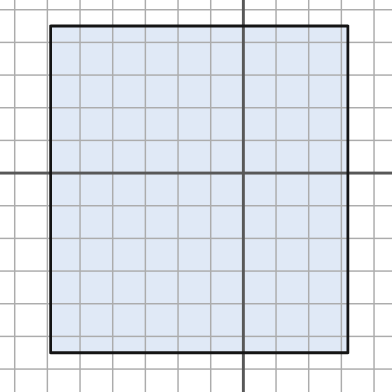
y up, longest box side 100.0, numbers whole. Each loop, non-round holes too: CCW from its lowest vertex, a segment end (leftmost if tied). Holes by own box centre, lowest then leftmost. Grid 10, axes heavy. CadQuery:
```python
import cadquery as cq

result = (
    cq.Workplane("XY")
    .moveTo(-59.0, -55.0)
    .lineTo(32.0, -55.0)
    .lineTo(32.0, 45.0)
    .lineTo(-59.0, 45.0)
    .close()
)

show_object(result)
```